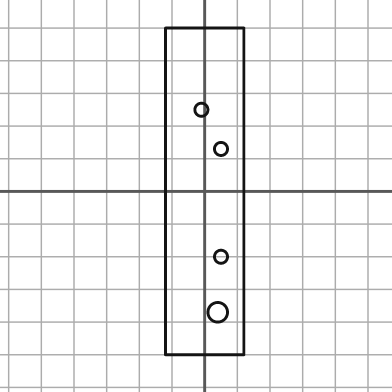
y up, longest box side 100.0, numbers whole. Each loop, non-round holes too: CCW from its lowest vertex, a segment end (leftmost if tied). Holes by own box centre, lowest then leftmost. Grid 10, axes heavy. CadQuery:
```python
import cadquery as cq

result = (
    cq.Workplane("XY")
    .moveTo(-12.0, -50.0)
    .lineTo(12.0, -50.0)
    .lineTo(12.0, 50.0)
    .lineTo(-12.0, 50.0)
    .close()
    .moveTo(4.0, -37.0)
    .circle(3.0)
    .moveTo(5.0, -20.0)
    .circle(2.0)
    .moveTo(5.0, 13.0)
    .circle(2.0)
    .moveTo(-1.0, 25.0)
    .circle(2.0)
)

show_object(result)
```